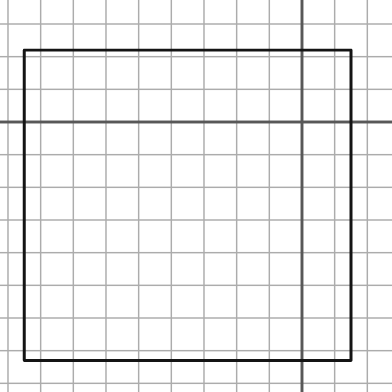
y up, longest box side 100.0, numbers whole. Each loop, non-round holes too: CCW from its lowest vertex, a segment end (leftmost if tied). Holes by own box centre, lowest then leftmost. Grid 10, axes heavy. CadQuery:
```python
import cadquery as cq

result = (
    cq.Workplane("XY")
    .moveTo(-85.0, -73.0)
    .lineTo(15.0, -73.0)
    .lineTo(15.0, 22.0)
    .lineTo(-85.0, 22.0)
    .close()
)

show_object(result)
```